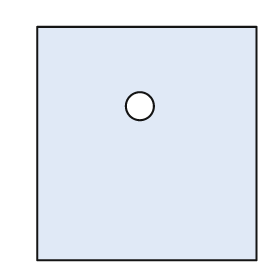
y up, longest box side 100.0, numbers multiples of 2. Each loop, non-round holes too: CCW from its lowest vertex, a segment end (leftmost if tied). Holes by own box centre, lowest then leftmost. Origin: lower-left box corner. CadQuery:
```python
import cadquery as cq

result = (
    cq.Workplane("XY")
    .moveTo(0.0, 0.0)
    .lineTo(94.0, 0.0)
    .lineTo(94.0, 100.0)
    .lineTo(0.0, 100.0)
    .close()
    .moveTo(44.0, 66.0)
    .circle(6.0)
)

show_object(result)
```